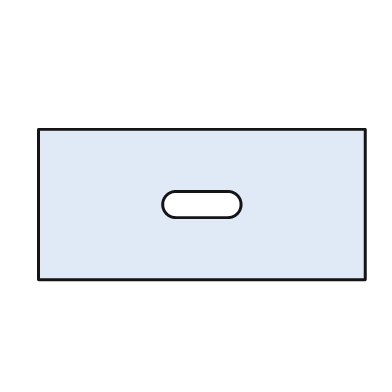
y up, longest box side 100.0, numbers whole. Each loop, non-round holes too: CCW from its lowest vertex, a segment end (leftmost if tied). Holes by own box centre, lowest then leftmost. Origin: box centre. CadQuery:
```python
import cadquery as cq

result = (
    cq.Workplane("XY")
    .moveTo(-50.0, -23.0)
    .lineTo(50.0, -23.0)
    .lineTo(50.0, 23.0)
    .lineTo(-50.0, 23.0)
    .close()
    .moveTo(-8.0, -4.0)
    .lineTo(8.0, -4.0)
    .threePointArc((12.0, 0.0), (8.0, 4.0))
    .lineTo(-8.0, 4.0)
    .threePointArc((-12.0, 0.0), (-8.0, -4.0))
    .close()
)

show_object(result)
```